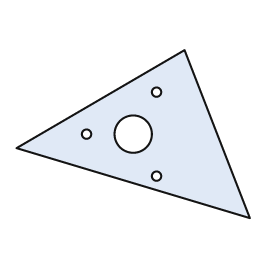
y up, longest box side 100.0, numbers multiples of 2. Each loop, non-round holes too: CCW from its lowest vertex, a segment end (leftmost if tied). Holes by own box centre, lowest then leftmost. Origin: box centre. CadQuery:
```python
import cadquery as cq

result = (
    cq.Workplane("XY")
    .moveTo(50.0, -36.0)
    .lineTo(22.0, 36.0)
    .lineTo(-50.0, -6.0)
    .close()
    .moveTo(10.0, -18.0)
    .circle(2.0)
    .moveTo(-20.0, 0.0)
    .circle(2.0)
    .moveTo(0.0, 0.0)
    .circle(8.0)
    .moveTo(10.0, 18.0)
    .circle(2.0)
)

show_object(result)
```